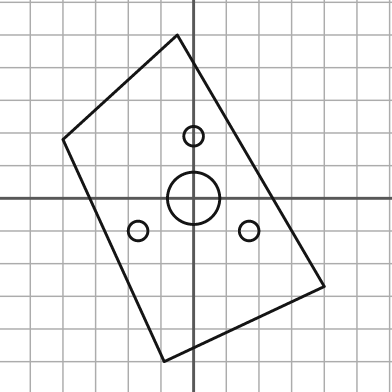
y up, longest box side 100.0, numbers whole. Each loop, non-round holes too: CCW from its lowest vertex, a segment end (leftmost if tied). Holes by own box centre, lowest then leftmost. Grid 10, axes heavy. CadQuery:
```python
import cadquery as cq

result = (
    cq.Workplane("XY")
    .moveTo(-9.0, -50.0)
    .lineTo(40.0, -27.0)
    .lineTo(-5.0, 50.0)
    .lineTo(-40.0, 18.0)
    .close()
    .moveTo(-17.0, -10.0)
    .circle(3.0)
    .moveTo(17.0, -10.0)
    .circle(3.0)
    .moveTo(0.0, 0.0)
    .circle(8.0)
    .moveTo(0.0, 19.0)
    .circle(3.0)
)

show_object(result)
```